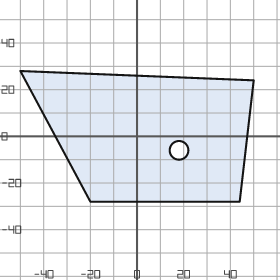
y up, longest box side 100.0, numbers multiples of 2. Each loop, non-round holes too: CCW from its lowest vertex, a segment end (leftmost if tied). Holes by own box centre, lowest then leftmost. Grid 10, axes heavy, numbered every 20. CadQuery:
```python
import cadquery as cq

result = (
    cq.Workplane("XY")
    .moveTo(-20.0, -28.0)
    .lineTo(44.0, -28.0)
    .lineTo(50.0, 24.0)
    .lineTo(-50.0, 28.0)
    .close()
    .moveTo(18.0, -6.0)
    .circle(4.0)
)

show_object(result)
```